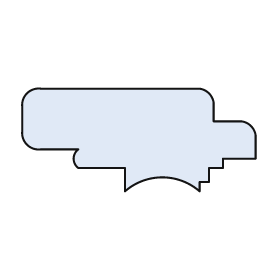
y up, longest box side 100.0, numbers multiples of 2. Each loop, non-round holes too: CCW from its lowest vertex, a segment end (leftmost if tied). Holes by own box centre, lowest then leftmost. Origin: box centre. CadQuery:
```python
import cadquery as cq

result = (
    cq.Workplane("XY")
    .moveTo(-6.0, -22.0)
    .threePointArc((10.0, -16.0), (26.0, -22.0))
    .lineTo(26.0, -18.0)
    .lineTo(30.0, -18.0)
    .lineTo(30.0, -12.0)
    .lineTo(36.0, -12.0)
    .lineTo(36.0, -8.0)
    .lineTo(50.0, -8.0)
    .lineTo(50.0, 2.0)
    .threePointArc((48.0, 6.0), (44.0, 8.0))
    .lineTo(32.0, 8.0)
    .lineTo(32.0, 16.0)
    .threePointArc((30.0, 20.0), (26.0, 22.0))
    .lineTo(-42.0, 22.0)
    .threePointArc((-48.0, 20.0), (-50.0, 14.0))
    .lineTo(-50.0, 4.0)
    .threePointArc((-48.0, -2.0), (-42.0, -4.0))
    .lineTo(-26.0, -4.0)
    .threePointArc((-28.0, -8.0), (-26.0, -12.0))
    .lineTo(-6.0, -12.0)
    .close()
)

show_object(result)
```